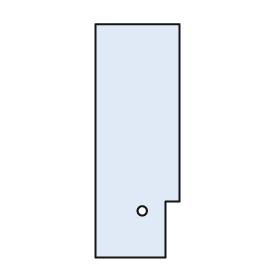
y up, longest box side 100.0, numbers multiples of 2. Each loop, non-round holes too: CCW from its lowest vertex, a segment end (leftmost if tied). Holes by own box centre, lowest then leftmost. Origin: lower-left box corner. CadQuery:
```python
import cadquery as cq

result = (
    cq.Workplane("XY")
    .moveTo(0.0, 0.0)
    .lineTo(30.0, 0.0)
    .lineTo(30.0, 24.0)
    .lineTo(36.0, 24.0)
    .lineTo(36.0, 100.0)
    .lineTo(0.0, 100.0)
    .close()
    .moveTo(20.0, 20.0)
    .circle(2.0)
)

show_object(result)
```